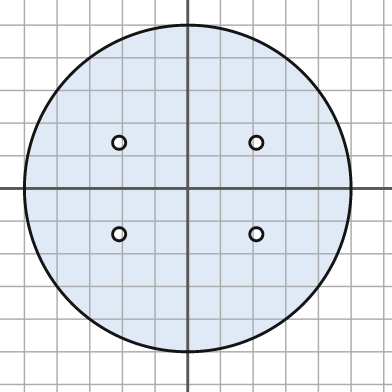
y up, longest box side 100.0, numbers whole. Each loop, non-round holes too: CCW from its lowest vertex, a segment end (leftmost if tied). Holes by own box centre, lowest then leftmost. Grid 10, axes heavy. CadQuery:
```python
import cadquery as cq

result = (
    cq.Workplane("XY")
    .moveTo(0.0, 0.0)
    .circle(50.0)
    .moveTo(-21.0, -14.0)
    .circle(2.0)
    .moveTo(21.0, -14.0)
    .circle(2.0)
    .moveTo(-21.0, 14.0)
    .circle(2.0)
    .moveTo(21.0, 14.0)
    .circle(2.0)
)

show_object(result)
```